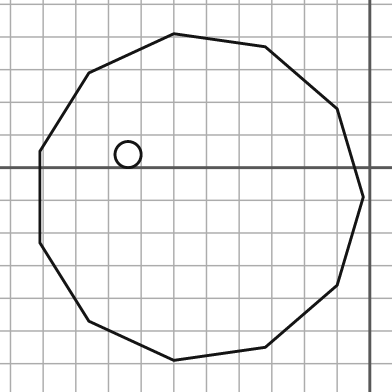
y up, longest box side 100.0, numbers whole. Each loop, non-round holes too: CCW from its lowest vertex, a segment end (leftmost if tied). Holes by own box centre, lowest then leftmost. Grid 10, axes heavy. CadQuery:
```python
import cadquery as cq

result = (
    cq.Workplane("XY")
    .moveTo(-60.0, -59.0)
    .lineTo(-32.0, -55.0)
    .lineTo(-10.0, -36.0)
    .lineTo(-2.0, -9.0)
    .lineTo(-10.0, 18.0)
    .lineTo(-32.0, 37.0)
    .lineTo(-60.0, 41.0)
    .lineTo(-86.0, 29.0)
    .lineTo(-101.0, 5.0)
    .lineTo(-101.0, -23.0)
    .lineTo(-86.0, -47.0)
    .close()
    .moveTo(-74.0, 4.0)
    .circle(4.0)
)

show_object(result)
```